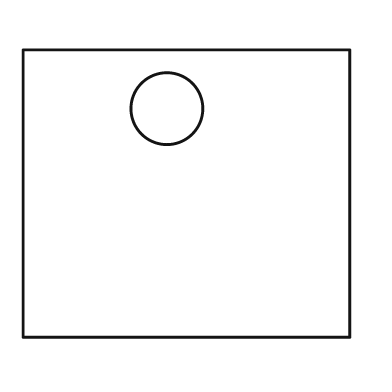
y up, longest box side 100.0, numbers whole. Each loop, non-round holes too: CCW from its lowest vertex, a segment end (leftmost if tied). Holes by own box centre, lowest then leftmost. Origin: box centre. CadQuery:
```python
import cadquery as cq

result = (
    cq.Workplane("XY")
    .moveTo(-50.0, -44.0)
    .lineTo(50.0, -44.0)
    .lineTo(50.0, 44.0)
    .lineTo(-50.0, 44.0)
    .close()
    .moveTo(-6.0, 26.0)
    .circle(11.0)
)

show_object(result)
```